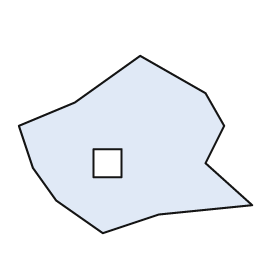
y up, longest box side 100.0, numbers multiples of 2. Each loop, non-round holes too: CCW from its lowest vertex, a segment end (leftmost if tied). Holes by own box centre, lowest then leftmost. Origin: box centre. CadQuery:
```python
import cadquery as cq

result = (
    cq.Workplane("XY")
    .moveTo(-14.0, -38.0)
    .lineTo(10.0, -30.0)
    .lineTo(50.0, -26.0)
    .lineTo(30.0, -8.0)
    .lineTo(38.0, 8.0)
    .lineTo(30.0, 22.0)
    .lineTo(2.0, 38.0)
    .lineTo(-26.0, 18.0)
    .lineTo(-50.0, 8.0)
    .lineTo(-44.0, -10.0)
    .lineTo(-34.0, -24.0)
    .close()
    .moveTo(-18.0, -14.0)
    .lineTo(-6.0, -14.0)
    .lineTo(-6.0, -2.0)
    .lineTo(-18.0, -2.0)
    .close()
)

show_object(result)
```